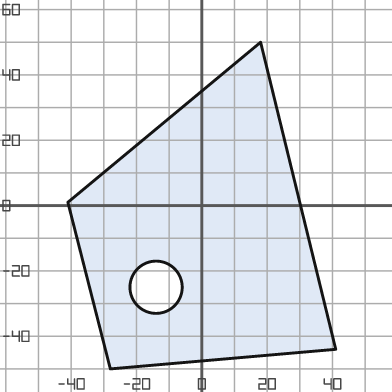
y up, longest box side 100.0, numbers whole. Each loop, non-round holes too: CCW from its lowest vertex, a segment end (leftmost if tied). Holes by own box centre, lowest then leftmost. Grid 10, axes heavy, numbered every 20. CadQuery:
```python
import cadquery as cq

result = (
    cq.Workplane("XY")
    .moveTo(-28.0, -50.0)
    .lineTo(41.0, -44.0)
    .lineTo(18.0, 50.0)
    .lineTo(-41.0, 1.0)
    .close()
    .moveTo(-14.0, -25.0)
    .circle(8.0)
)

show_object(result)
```